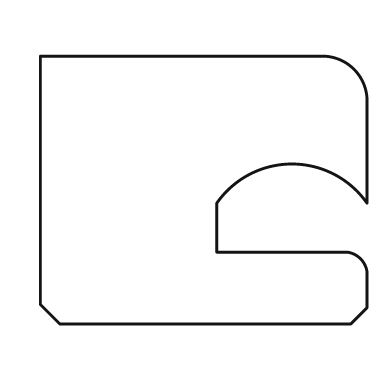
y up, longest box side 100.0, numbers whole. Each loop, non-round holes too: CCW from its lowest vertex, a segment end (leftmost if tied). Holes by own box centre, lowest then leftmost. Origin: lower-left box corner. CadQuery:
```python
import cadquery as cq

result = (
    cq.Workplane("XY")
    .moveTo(6.0, 0.0)
    .lineTo(95.0, 0.0)
    .lineTo(100.0, 5.0)
    .lineTo(100.0, 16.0)
    .threePointArc((98.0, 20.0), (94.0, 22.0))
    .lineTo(54.0, 22.0)
    .lineTo(54.0, 37.0)
    .threePointArc((77.0, 49.0), (100.0, 37.0))
    .lineTo(100.0, 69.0)
    .threePointArc((96.0, 78.0), (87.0, 82.0))
    .lineTo(0.0, 82.0)
    .lineTo(0.0, 6.0)
    .close()
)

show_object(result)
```